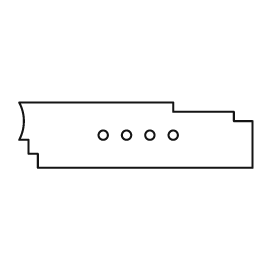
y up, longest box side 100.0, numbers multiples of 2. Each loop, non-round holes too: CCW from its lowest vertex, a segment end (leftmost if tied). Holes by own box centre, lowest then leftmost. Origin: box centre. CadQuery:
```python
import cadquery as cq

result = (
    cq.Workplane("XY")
    .moveTo(-42.0, -14.0)
    .lineTo(50.0, -14.0)
    .lineTo(50.0, 6.0)
    .lineTo(42.0, 6.0)
    .lineTo(42.0, 10.0)
    .lineTo(16.0, 10.0)
    .lineTo(16.0, 14.0)
    .lineTo(-50.0, 14.0)
    .threePointArc((-48.0, 6.0), (-50.0, -2.0))
    .lineTo(-46.0, -2.0)
    .lineTo(-46.0, -8.0)
    .lineTo(-42.0, -8.0)
    .close()
    .moveTo(-14.0, 0.0)
    .circle(2.0)
    .moveTo(-4.0, 0.0)
    .circle(2.0)
    .moveTo(6.0, 0.0)
    .circle(2.0)
    .moveTo(16.0, 0.0)
    .circle(2.0)
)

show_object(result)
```